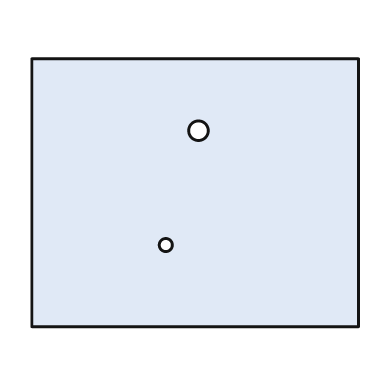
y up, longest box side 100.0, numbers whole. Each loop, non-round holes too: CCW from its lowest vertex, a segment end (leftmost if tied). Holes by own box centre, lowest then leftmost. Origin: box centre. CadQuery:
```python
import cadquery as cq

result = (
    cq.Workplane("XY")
    .moveTo(-50.0, -41.0)
    .lineTo(50.0, -41.0)
    .lineTo(50.0, 41.0)
    .lineTo(-50.0, 41.0)
    .close()
    .moveTo(-9.0, -16.0)
    .circle(2.0)
    .moveTo(1.0, 19.0)
    .circle(3.0)
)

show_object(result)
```